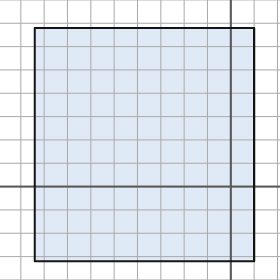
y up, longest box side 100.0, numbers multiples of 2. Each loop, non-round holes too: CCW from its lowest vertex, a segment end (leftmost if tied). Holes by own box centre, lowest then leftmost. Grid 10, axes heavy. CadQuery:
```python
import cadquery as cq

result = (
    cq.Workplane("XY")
    .moveTo(-84.0, -32.0)
    .lineTo(10.0, -32.0)
    .lineTo(10.0, 68.0)
    .lineTo(-84.0, 68.0)
    .close()
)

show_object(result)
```